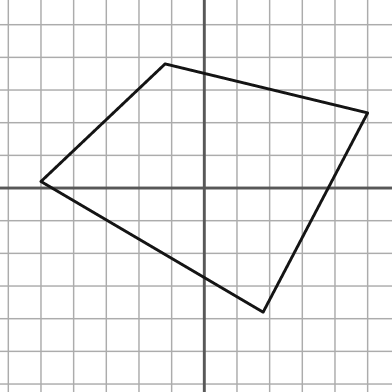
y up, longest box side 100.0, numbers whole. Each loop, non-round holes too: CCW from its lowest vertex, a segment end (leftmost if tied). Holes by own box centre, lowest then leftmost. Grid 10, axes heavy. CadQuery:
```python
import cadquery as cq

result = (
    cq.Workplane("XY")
    .moveTo(18.0, -38.0)
    .lineTo(50.0, 23.0)
    .lineTo(-12.0, 38.0)
    .lineTo(-50.0, 2.0)
    .close()
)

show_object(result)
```